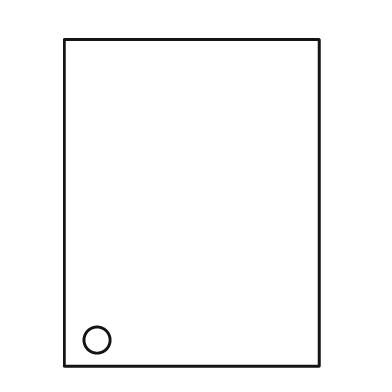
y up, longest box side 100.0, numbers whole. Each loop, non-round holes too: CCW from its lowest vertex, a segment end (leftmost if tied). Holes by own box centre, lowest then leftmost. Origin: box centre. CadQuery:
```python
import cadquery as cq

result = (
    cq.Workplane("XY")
    .moveTo(-39.0, -50.0)
    .lineTo(39.0, -50.0)
    .lineTo(39.0, 50.0)
    .lineTo(-39.0, 50.0)
    .close()
    .moveTo(-29.0, -42.0)
    .circle(4.0)
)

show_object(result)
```